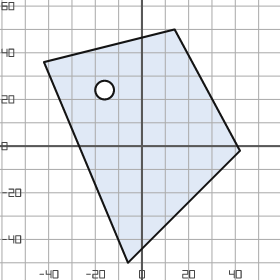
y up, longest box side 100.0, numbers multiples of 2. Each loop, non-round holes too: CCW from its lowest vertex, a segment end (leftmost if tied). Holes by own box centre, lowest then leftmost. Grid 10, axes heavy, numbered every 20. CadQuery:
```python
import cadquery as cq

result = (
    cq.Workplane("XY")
    .moveTo(-6.0, -50.0)
    .lineTo(42.0, -2.0)
    .lineTo(14.0, 50.0)
    .lineTo(-42.0, 36.0)
    .close()
    .moveTo(-16.0, 24.0)
    .circle(4.0)
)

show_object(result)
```